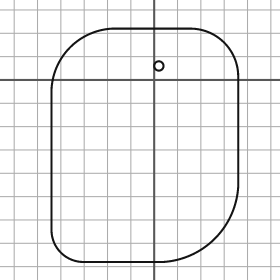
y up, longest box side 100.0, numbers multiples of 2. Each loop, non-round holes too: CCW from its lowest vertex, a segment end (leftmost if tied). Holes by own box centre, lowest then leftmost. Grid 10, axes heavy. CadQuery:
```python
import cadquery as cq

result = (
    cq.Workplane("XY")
    .moveTo(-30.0, -78.0)
    .lineTo(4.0, -78.0)
    .threePointArc((26.0, -68.0), (36.0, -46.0))
    .lineTo(36.0, 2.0)
    .threePointArc((30.0, 16.0), (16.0, 22.0))
    .lineTo(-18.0, 22.0)
    .threePointArc((-36.0, 14.0), (-44.0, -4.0))
    .lineTo(-44.0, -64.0)
    .threePointArc((-40.0, -74.0), (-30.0, -78.0))
    .close()
    .moveTo(2.0, 6.0)
    .circle(2.0)
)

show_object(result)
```